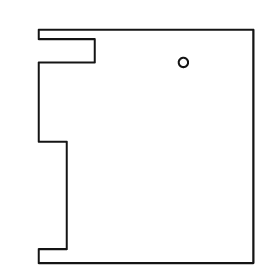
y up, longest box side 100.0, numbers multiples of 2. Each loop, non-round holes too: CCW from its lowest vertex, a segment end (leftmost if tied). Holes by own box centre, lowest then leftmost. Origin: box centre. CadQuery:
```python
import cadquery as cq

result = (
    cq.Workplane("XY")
    .moveTo(-46.0, -50.0)
    .lineTo(46.0, -50.0)
    .lineTo(46.0, 50.0)
    .lineTo(-46.0, 50.0)
    .lineTo(-46.0, 46.0)
    .lineTo(-22.0, 46.0)
    .lineTo(-22.0, 36.0)
    .lineTo(-46.0, 36.0)
    .lineTo(-46.0, 2.0)
    .lineTo(-34.0, 2.0)
    .lineTo(-34.0, -44.0)
    .lineTo(-46.0, -44.0)
    .close()
    .moveTo(16.0, 36.0)
    .circle(2.0)
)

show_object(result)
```